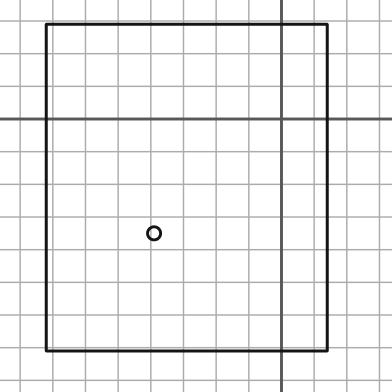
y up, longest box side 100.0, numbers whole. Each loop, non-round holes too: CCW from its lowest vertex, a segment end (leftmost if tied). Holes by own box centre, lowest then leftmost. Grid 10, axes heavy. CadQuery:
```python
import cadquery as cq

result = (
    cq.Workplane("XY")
    .moveTo(-72.0, -71.0)
    .lineTo(14.0, -71.0)
    .lineTo(14.0, 29.0)
    .lineTo(-72.0, 29.0)
    .close()
    .moveTo(-39.0, -35.0)
    .circle(2.0)
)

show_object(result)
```